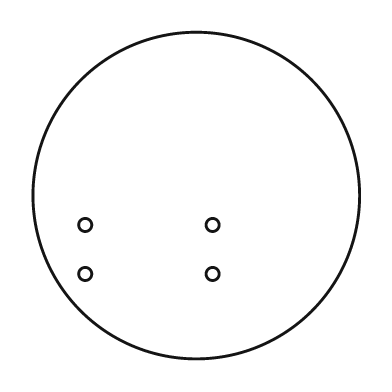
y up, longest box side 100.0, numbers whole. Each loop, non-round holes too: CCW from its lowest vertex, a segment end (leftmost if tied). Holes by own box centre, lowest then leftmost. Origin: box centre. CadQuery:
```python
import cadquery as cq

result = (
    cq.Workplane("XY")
    .moveTo(0.0, 0.0)
    .circle(50.0)
    .moveTo(-34.0, -24.0)
    .circle(2.0)
    .moveTo(5.0, -24.0)
    .circle(2.0)
    .moveTo(-34.0, -9.0)
    .circle(2.0)
    .moveTo(5.0, -9.0)
    .circle(2.0)
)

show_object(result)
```